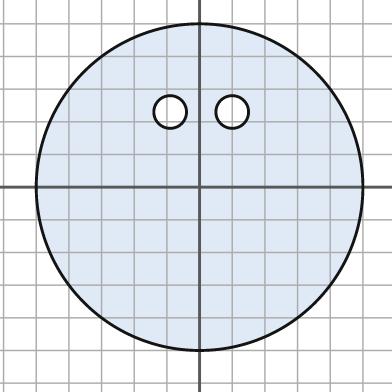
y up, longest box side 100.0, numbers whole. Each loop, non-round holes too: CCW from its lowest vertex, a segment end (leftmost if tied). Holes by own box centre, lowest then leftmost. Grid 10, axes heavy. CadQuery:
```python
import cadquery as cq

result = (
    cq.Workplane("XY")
    .moveTo(0.0, 0.0)
    .circle(50.0)
    .moveTo(-9.0, 23.0)
    .circle(5.0)
    .moveTo(10.0, 23.0)
    .circle(5.0)
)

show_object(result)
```